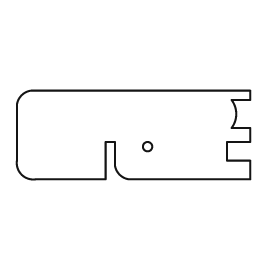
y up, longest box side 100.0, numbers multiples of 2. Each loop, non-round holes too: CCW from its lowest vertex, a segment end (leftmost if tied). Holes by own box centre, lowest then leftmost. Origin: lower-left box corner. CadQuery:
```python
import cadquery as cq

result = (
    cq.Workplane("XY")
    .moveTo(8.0, 0.0)
    .lineTo(38.0, 0.0)
    .lineTo(38.0, 16.0)
    .lineTo(42.0, 16.0)
    .lineTo(42.0, 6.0)
    .threePointArc((44.0, 2.0), (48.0, 0.0))
    .lineTo(100.0, 0.0)
    .lineTo(100.0, 8.0)
    .lineTo(90.0, 8.0)
    .lineTo(90.0, 16.0)
    .lineTo(100.0, 16.0)
    .lineTo(100.0, 22.0)
    .lineTo(92.0, 22.0)
    .threePointArc((94.0, 28.0), (92.0, 34.0))
    .lineTo(100.0, 34.0)
    .lineTo(100.0, 38.0)
    .lineTo(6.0, 38.0)
    .threePointArc((2.0, 36.0), (0.0, 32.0))
    .lineTo(0.0, 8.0)
    .threePointArc((2.0, 2.0), (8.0, 0.0))
    .close()
    .moveTo(56.0, 14.0)
    .circle(2.0)
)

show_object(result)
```